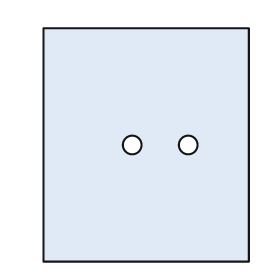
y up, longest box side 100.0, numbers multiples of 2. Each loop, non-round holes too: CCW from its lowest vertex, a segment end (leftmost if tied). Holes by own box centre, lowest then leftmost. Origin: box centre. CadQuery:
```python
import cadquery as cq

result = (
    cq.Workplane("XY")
    .moveTo(-44.0, -50.0)
    .lineTo(44.0, -50.0)
    .lineTo(44.0, 50.0)
    .lineTo(-44.0, 50.0)
    .close()
    .moveTo(-6.0, 0.0)
    .circle(4.0)
    .moveTo(18.0, 0.0)
    .circle(4.0)
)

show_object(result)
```